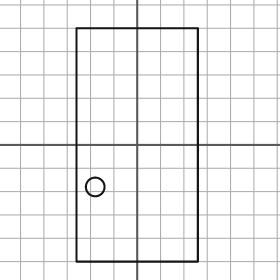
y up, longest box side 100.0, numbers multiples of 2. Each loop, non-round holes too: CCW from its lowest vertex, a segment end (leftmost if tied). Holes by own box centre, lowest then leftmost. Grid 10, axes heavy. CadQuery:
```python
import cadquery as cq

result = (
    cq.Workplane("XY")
    .moveTo(-26.0, -50.0)
    .lineTo(26.0, -50.0)
    .lineTo(26.0, 50.0)
    .lineTo(-26.0, 50.0)
    .close()
    .moveTo(-18.0, -18.0)
    .circle(4.0)
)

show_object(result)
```